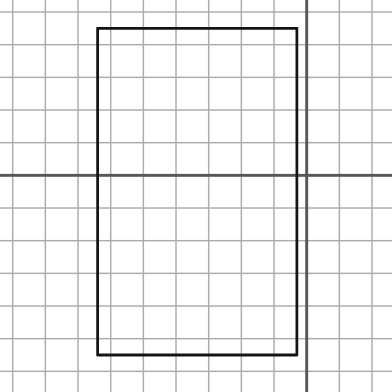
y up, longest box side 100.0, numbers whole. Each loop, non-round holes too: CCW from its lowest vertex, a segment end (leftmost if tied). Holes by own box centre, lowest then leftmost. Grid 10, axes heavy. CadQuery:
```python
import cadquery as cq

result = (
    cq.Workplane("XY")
    .moveTo(-64.0, -55.0)
    .lineTo(-3.0, -55.0)
    .lineTo(-3.0, 45.0)
    .lineTo(-64.0, 45.0)
    .close()
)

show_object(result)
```